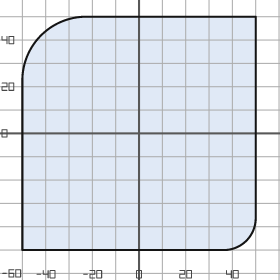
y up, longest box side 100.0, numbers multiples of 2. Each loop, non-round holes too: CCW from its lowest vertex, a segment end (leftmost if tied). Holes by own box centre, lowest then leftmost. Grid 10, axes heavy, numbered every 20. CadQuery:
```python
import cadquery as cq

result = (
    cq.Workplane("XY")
    .moveTo(-50.0, -50.0)
    .lineTo(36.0, -50.0)
    .threePointArc((46.0, -46.0), (50.0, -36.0))
    .lineTo(50.0, 50.0)
    .lineTo(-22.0, 50.0)
    .threePointArc((-42.0, 42.0), (-50.0, 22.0))
    .close()
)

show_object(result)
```